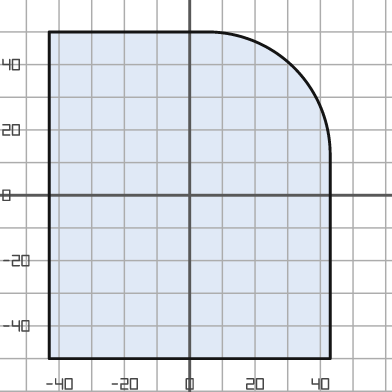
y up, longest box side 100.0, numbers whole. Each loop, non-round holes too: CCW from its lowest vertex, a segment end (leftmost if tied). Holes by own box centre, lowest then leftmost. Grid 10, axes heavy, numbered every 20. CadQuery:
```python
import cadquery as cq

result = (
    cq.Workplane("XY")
    .moveTo(-43.0, -50.0)
    .lineTo(43.0, -50.0)
    .lineTo(43.0, 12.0)
    .threePointArc((32.0, 39.0), (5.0, 50.0))
    .lineTo(-43.0, 50.0)
    .close()
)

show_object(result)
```